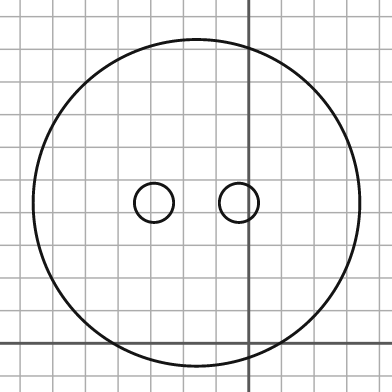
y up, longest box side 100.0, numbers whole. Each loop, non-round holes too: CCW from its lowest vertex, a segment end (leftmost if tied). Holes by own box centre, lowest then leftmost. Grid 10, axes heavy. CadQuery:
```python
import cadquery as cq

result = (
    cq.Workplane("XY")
    .moveTo(-16.0, 43.0)
    .circle(50.0)
    .moveTo(-29.0, 43.0)
    .circle(6.0)
    .moveTo(-3.0, 43.0)
    .circle(6.0)
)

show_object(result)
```